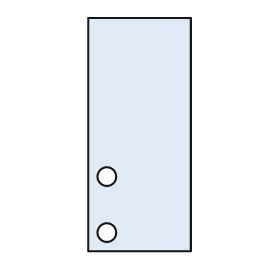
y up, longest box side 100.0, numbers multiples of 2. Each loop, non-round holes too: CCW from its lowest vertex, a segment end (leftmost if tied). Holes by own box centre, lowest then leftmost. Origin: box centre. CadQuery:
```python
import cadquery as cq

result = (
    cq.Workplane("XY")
    .moveTo(-22.0, -50.0)
    .lineTo(22.0, -50.0)
    .lineTo(22.0, 50.0)
    .lineTo(-22.0, 50.0)
    .close()
    .moveTo(-14.0, -42.0)
    .circle(4.0)
    .moveTo(-14.0, -18.0)
    .circle(4.0)
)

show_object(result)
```